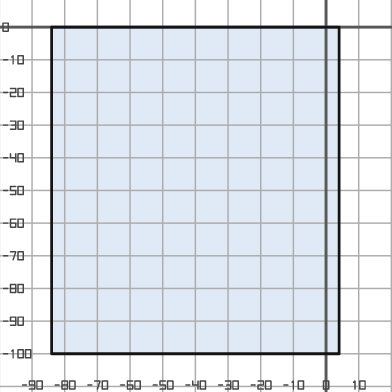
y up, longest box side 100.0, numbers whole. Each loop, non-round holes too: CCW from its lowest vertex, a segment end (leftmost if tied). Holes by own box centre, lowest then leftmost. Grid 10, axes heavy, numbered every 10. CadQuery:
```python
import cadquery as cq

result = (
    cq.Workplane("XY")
    .moveTo(-84.0, -100.0)
    .lineTo(4.0, -100.0)
    .lineTo(4.0, 0.0)
    .lineTo(-84.0, 0.0)
    .close()
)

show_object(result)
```